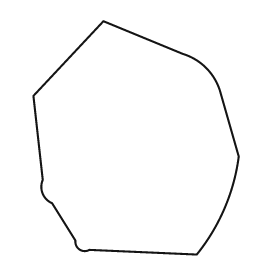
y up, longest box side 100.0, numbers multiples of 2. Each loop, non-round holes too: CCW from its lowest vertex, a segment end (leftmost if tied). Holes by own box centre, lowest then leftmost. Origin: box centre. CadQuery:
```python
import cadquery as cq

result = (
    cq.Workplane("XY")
    .moveTo(26.0, -50.0)
    .threePointArc((38.0, -30.0), (44.0, -8.0))
    .lineTo(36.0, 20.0)
    .threePointArc((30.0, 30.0), (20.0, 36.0))
    .lineTo(-14.0, 50.0)
    .lineTo(-44.0, 18.0)
    .lineTo(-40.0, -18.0)
    .threePointArc((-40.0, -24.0), (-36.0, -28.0))
    .lineTo(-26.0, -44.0)
    .threePointArc((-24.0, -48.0), (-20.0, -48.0))
    .close()
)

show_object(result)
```